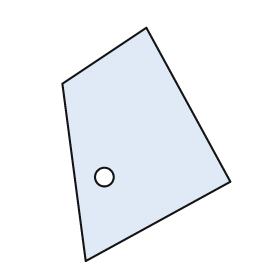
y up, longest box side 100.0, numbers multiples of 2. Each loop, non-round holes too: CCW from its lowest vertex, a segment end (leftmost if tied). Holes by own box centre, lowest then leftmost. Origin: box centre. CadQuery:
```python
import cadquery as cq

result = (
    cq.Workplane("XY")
    .moveTo(-26.0, -50.0)
    .lineTo(36.0, -16.0)
    .lineTo(0.0, 50.0)
    .lineTo(-36.0, 26.0)
    .close()
    .moveTo(-18.0, -14.0)
    .circle(4.0)
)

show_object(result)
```